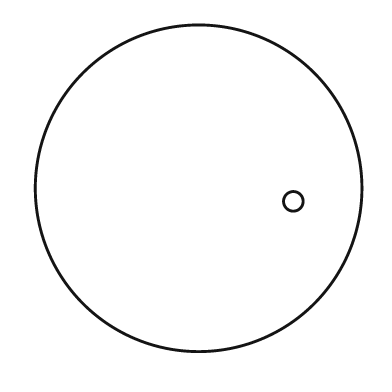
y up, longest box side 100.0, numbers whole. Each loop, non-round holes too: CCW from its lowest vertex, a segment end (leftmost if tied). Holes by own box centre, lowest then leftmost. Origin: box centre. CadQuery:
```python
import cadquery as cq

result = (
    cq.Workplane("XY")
    .moveTo(0.0, 0.0)
    .circle(50.0)
    .moveTo(29.0, -4.0)
    .circle(3.0)
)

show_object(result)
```